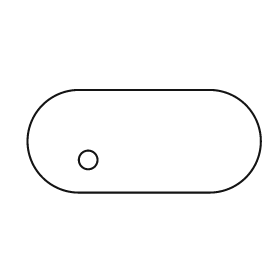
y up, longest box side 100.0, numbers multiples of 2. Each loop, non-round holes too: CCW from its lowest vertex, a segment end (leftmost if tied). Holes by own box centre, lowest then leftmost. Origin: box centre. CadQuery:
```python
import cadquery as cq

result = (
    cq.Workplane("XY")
    .moveTo(-28.0, -22.0)
    .lineTo(28.0, -22.0)
    .threePointArc((50.0, 0.0), (28.0, 22.0))
    .lineTo(-28.0, 22.0)
    .threePointArc((-50.0, 0.0), (-28.0, -22.0))
    .close()
    .moveTo(-24.0, -8.0)
    .circle(4.0)
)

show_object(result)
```